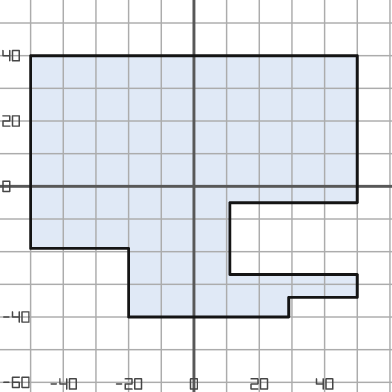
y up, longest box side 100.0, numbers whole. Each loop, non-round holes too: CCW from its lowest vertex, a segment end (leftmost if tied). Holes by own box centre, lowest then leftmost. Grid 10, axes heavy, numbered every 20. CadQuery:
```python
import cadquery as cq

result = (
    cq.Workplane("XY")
    .moveTo(-20.0, -40.0)
    .lineTo(29.0, -40.0)
    .lineTo(29.0, -34.0)
    .lineTo(50.0, -34.0)
    .lineTo(50.0, -27.0)
    .lineTo(11.0, -27.0)
    .lineTo(11.0, -5.0)
    .lineTo(50.0, -5.0)
    .lineTo(50.0, 40.0)
    .lineTo(-50.0, 40.0)
    .lineTo(-50.0, -19.0)
    .lineTo(-20.0, -19.0)
    .close()
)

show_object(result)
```